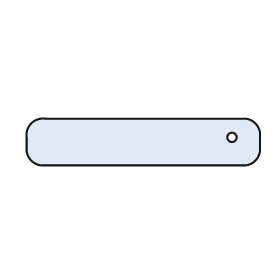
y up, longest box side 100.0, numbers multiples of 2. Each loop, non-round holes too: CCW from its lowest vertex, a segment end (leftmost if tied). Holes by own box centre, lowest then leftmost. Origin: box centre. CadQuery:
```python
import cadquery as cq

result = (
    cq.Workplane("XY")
    .moveTo(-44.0, -10.0)
    .lineTo(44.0, -10.0)
    .threePointArc((48.0, -8.0), (50.0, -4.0))
    .lineTo(50.0, 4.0)
    .threePointArc((48.0, 8.0), (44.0, 10.0))
    .lineTo(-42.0, 10.0)
    .threePointArc((-48.0, 8.0), (-50.0, 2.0))
    .lineTo(-50.0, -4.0)
    .threePointArc((-48.0, -8.0), (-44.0, -10.0))
    .close()
    .moveTo(38.0, 2.0)
    .circle(2.0)
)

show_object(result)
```